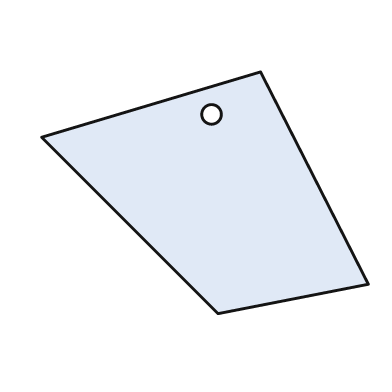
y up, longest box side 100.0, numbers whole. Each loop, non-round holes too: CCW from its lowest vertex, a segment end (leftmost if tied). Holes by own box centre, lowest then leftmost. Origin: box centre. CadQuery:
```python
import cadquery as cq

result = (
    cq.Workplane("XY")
    .moveTo(4.0, -37.0)
    .lineTo(50.0, -28.0)
    .lineTo(17.0, 37.0)
    .lineTo(-50.0, 17.0)
    .close()
    .moveTo(2.0, 24.0)
    .circle(3.0)
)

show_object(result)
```